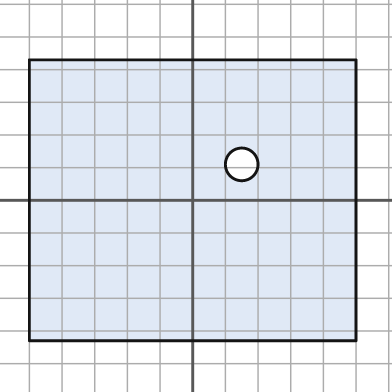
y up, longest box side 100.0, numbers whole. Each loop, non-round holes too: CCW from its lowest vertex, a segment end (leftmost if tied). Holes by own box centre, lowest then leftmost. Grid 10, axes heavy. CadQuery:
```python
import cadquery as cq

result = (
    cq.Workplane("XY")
    .moveTo(-50.0, -43.0)
    .lineTo(50.0, -43.0)
    .lineTo(50.0, 43.0)
    .lineTo(-50.0, 43.0)
    .close()
    .moveTo(15.0, 11.0)
    .circle(5.0)
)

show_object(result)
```